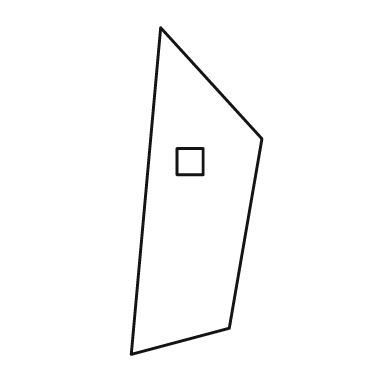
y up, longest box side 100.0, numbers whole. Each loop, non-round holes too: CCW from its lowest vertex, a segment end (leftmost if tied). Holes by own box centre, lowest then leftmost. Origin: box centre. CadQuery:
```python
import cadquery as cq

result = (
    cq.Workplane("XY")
    .moveTo(-20.0, -50.0)
    .lineTo(10.0, -42.0)
    .lineTo(20.0, 16.0)
    .lineTo(-11.0, 50.0)
    .close()
    .moveTo(-6.0, 5.0)
    .lineTo(2.0, 5.0)
    .lineTo(2.0, 13.0)
    .lineTo(-6.0, 13.0)
    .close()
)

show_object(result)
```